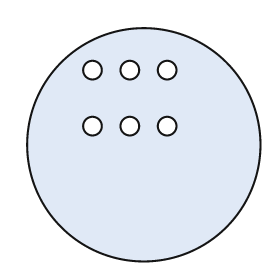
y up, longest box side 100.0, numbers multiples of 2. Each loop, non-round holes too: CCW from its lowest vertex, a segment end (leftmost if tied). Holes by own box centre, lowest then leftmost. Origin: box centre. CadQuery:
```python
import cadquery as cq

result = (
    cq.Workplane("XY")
    .moveTo(0.0, 0.0)
    .circle(50.0)
    .moveTo(-22.0, 8.0)
    .circle(4.0)
    .moveTo(-6.0, 8.0)
    .circle(4.0)
    .moveTo(10.0, 8.0)
    .circle(4.0)
    .moveTo(-22.0, 32.0)
    .circle(4.0)
    .moveTo(-6.0, 32.0)
    .circle(4.0)
    .moveTo(10.0, 32.0)
    .circle(4.0)
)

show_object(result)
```